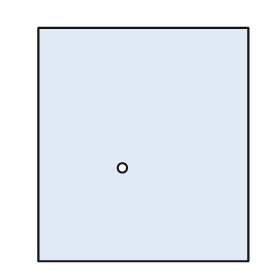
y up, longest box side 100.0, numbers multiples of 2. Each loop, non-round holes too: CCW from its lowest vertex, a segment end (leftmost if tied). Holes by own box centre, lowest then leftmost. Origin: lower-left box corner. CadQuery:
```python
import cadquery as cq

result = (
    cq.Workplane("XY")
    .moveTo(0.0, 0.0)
    .lineTo(90.0, 0.0)
    .lineTo(90.0, 100.0)
    .lineTo(0.0, 100.0)
    .close()
    .moveTo(36.0, 40.0)
    .circle(2.0)
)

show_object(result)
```